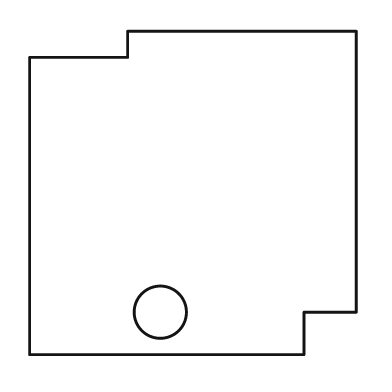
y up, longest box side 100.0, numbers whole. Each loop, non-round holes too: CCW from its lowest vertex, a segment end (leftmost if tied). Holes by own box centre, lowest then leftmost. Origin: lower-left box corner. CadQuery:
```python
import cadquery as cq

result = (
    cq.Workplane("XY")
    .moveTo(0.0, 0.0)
    .lineTo(84.0, 0.0)
    .lineTo(84.0, 13.0)
    .lineTo(100.0, 13.0)
    .lineTo(100.0, 99.0)
    .lineTo(30.0, 99.0)
    .lineTo(30.0, 91.0)
    .lineTo(0.0, 91.0)
    .close()
    .moveTo(40.0, 13.0)
    .circle(8.0)
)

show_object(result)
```